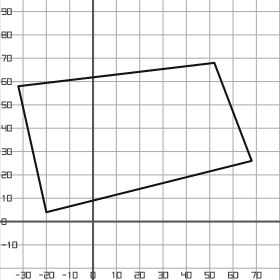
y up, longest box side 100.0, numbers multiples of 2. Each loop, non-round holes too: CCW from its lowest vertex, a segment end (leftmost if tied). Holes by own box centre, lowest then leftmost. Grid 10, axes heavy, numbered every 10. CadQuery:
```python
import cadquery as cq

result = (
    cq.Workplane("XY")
    .moveTo(-20.0, 4.0)
    .lineTo(68.0, 26.0)
    .lineTo(52.0, 68.0)
    .lineTo(-32.0, 58.0)
    .close()
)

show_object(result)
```